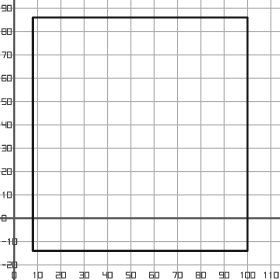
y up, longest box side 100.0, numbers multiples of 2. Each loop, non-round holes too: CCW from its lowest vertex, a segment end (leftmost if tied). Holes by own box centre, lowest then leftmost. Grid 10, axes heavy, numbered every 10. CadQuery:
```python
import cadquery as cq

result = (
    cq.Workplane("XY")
    .moveTo(8.0, -14.0)
    .lineTo(100.0, -14.0)
    .lineTo(100.0, 86.0)
    .lineTo(8.0, 86.0)
    .close()
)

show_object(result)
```